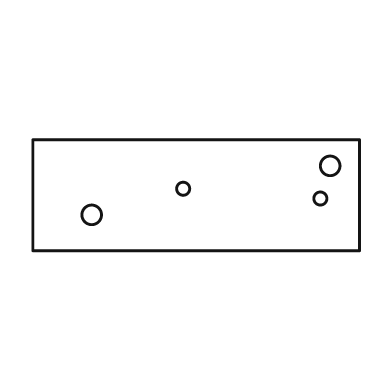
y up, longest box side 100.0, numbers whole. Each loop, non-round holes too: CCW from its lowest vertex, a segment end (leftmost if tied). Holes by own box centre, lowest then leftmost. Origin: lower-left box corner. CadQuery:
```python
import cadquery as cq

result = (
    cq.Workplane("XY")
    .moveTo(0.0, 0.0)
    .lineTo(100.0, 0.0)
    .lineTo(100.0, 34.0)
    .lineTo(0.0, 34.0)
    .close()
    .moveTo(18.0, 11.0)
    .circle(3.0)
    .moveTo(88.0, 16.0)
    .circle(2.0)
    .moveTo(46.0, 19.0)
    .circle(2.0)
    .moveTo(91.0, 26.0)
    .circle(3.0)
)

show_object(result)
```